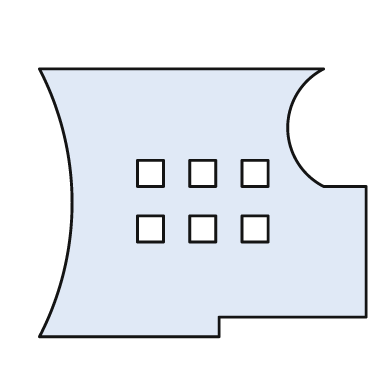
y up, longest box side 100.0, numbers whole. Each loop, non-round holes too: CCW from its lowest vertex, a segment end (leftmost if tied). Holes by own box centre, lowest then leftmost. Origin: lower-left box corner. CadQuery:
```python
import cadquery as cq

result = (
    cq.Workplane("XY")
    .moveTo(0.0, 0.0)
    .lineTo(55.0, 0.0)
    .lineTo(55.0, 6.0)
    .lineTo(100.0, 6.0)
    .lineTo(100.0, 46.0)
    .lineTo(87.0, 46.0)
    .threePointArc((76.0, 64.0), (87.0, 82.0))
    .lineTo(0.0, 82.0)
    .threePointArc((10.0, 41.0), (0.0, 0.0))
    .close()
    .moveTo(30.0, 29.0)
    .lineTo(38.0, 29.0)
    .lineTo(38.0, 37.0)
    .lineTo(30.0, 37.0)
    .close()
    .moveTo(46.0, 29.0)
    .lineTo(54.0, 29.0)
    .lineTo(54.0, 37.0)
    .lineTo(46.0, 37.0)
    .close()
    .moveTo(62.0, 29.0)
    .lineTo(70.0, 29.0)
    .lineTo(70.0, 37.0)
    .lineTo(62.0, 37.0)
    .close()
    .moveTo(30.0, 46.0)
    .lineTo(38.0, 46.0)
    .lineTo(38.0, 54.0)
    .lineTo(30.0, 54.0)
    .close()
    .moveTo(46.0, 46.0)
    .lineTo(54.0, 46.0)
    .lineTo(54.0, 54.0)
    .lineTo(46.0, 54.0)
    .close()
    .moveTo(62.0, 46.0)
    .lineTo(70.0, 46.0)
    .lineTo(70.0, 54.0)
    .lineTo(62.0, 54.0)
    .close()
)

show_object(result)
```